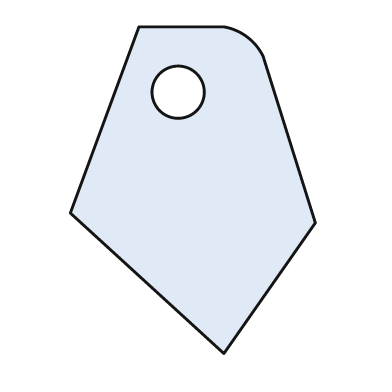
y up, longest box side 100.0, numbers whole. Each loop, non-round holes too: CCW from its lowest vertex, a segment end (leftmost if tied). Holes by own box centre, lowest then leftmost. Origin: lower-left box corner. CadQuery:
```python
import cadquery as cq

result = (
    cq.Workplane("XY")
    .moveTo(47.0, 0.0)
    .lineTo(75.0, 40.0)
    .lineTo(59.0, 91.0)
    .threePointArc((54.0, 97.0), (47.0, 100.0))
    .lineTo(21.0, 100.0)
    .lineTo(0.0, 43.0)
    .close()
    .moveTo(33.0, 80.0)
    .circle(8.0)
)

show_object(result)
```